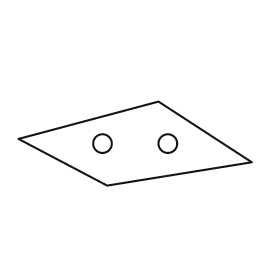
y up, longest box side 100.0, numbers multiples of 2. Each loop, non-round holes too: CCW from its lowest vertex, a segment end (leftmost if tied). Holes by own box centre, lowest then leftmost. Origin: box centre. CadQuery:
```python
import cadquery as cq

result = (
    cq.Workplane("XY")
    .moveTo(-12.0, -18.0)
    .lineTo(50.0, -8.0)
    .lineTo(10.0, 18.0)
    .lineTo(-50.0, 2.0)
    .close()
    .moveTo(-14.0, 0.0)
    .circle(4.0)
    .moveTo(14.0, 0.0)
    .circle(4.0)
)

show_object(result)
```